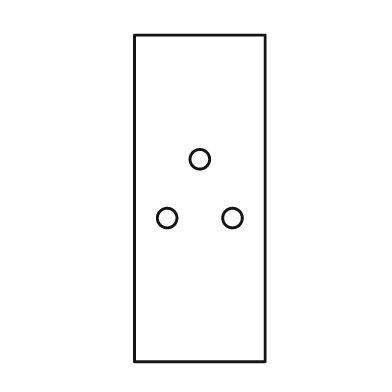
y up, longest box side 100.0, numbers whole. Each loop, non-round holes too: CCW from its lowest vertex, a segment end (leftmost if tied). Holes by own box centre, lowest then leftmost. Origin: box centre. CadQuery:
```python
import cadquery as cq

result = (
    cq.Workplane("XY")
    .moveTo(-20.0, -50.0)
    .lineTo(20.0, -50.0)
    .lineTo(20.0, 50.0)
    .lineTo(-20.0, 50.0)
    .close()
    .moveTo(-10.0, -6.0)
    .circle(3.0)
    .moveTo(10.0, -6.0)
    .circle(3.0)
    .moveTo(0.0, 12.0)
    .circle(3.0)
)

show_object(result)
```